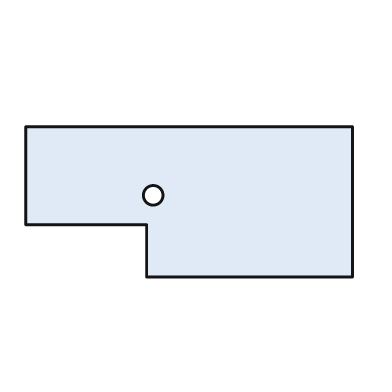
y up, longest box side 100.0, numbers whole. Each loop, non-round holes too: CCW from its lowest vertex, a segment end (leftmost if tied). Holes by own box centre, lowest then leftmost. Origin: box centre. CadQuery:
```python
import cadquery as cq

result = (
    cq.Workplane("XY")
    .moveTo(-13.0, -23.0)
    .lineTo(50.0, -23.0)
    .lineTo(50.0, 23.0)
    .lineTo(-50.0, 23.0)
    .lineTo(-50.0, -7.0)
    .lineTo(-13.0, -7.0)
    .close()
    .moveTo(-11.0, 2.0)
    .circle(3.0)
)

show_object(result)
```